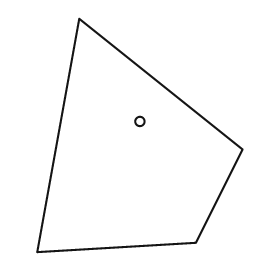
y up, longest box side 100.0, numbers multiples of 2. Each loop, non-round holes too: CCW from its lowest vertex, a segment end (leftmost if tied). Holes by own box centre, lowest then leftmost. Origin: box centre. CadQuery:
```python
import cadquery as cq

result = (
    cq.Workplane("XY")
    .moveTo(-44.0, -50.0)
    .lineTo(24.0, -46.0)
    .lineTo(44.0, -6.0)
    .lineTo(-26.0, 50.0)
    .close()
    .moveTo(0.0, 6.0)
    .circle(2.0)
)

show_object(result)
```